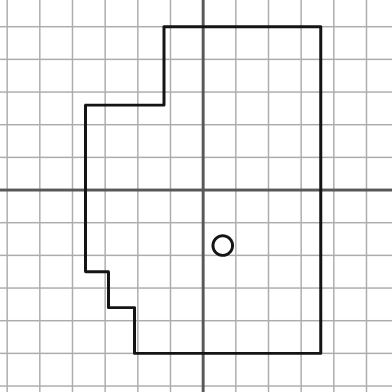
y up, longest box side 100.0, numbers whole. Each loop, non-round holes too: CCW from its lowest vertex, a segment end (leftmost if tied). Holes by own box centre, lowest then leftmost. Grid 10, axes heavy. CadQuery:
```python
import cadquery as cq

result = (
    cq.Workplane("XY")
    .moveTo(-21.0, -50.0)
    .lineTo(36.0, -50.0)
    .lineTo(36.0, 50.0)
    .lineTo(-12.0, 50.0)
    .lineTo(-12.0, 26.0)
    .lineTo(-36.0, 26.0)
    .lineTo(-36.0, -25.0)
    .lineTo(-29.0, -25.0)
    .lineTo(-29.0, -36.0)
    .lineTo(-21.0, -36.0)
    .close()
    .moveTo(6.0, -17.0)
    .circle(3.0)
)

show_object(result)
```